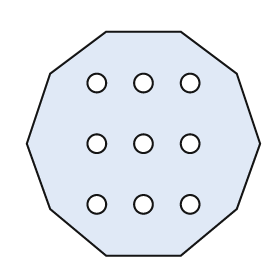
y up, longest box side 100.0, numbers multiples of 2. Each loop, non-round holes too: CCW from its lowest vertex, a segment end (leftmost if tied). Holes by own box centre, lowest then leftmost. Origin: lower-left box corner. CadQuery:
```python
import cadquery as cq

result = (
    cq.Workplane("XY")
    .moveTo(34.0, 0.0)
    .lineTo(66.0, 0.0)
    .lineTo(90.0, 20.0)
    .lineTo(100.0, 48.0)
    .lineTo(90.0, 78.0)
    .lineTo(66.0, 96.0)
    .lineTo(34.0, 96.0)
    .lineTo(10.0, 78.0)
    .lineTo(0.0, 48.0)
    .lineTo(10.0, 20.0)
    .close()
    .moveTo(30.0, 22.0)
    .circle(4.0)
    .moveTo(50.0, 22.0)
    .circle(4.0)
    .moveTo(70.0, 22.0)
    .circle(4.0)
    .moveTo(30.0, 48.0)
    .circle(4.0)
    .moveTo(50.0, 48.0)
    .circle(4.0)
    .moveTo(70.0, 48.0)
    .circle(4.0)
    .moveTo(30.0, 74.0)
    .circle(4.0)
    .moveTo(50.0, 74.0)
    .circle(4.0)
    .moveTo(70.0, 74.0)
    .circle(4.0)
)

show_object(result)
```